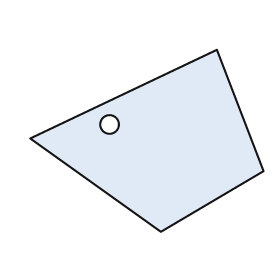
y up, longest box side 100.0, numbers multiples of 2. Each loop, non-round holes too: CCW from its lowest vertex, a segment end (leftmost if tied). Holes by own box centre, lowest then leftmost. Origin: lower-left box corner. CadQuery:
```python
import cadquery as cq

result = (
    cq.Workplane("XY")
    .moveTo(56.0, 0.0)
    .lineTo(100.0, 26.0)
    .lineTo(80.0, 78.0)
    .lineTo(0.0, 40.0)
    .close()
    .moveTo(34.0, 46.0)
    .circle(4.0)
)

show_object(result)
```